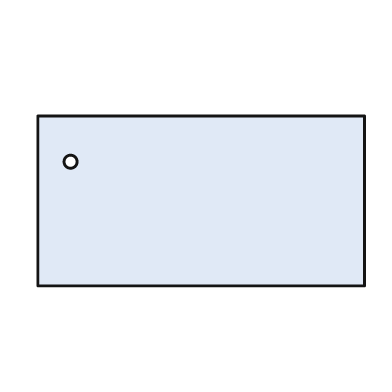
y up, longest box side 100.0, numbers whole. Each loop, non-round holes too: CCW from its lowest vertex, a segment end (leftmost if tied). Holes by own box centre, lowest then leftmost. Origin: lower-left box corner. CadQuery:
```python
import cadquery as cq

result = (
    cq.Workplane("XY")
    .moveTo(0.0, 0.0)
    .lineTo(100.0, 0.0)
    .lineTo(100.0, 52.0)
    .lineTo(0.0, 52.0)
    .close()
    .moveTo(10.0, 38.0)
    .circle(2.0)
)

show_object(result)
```